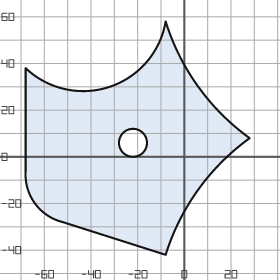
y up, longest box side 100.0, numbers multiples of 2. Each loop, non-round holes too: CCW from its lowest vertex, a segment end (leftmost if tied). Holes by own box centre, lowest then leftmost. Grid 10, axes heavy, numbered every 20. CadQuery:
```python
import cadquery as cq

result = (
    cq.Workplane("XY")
    .moveTo(-8.0, -42.0)
    .threePointArc((6.0, -14.0), (28.0, 8.0))
    .threePointArc((6.0, 30.0), (-8.0, 58.0))
    .threePointArc((-32.0, 30.0), (-68.0, 38.0))
    .lineTo(-68.0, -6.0)
    .threePointArc((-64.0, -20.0), (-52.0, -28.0))
    .close()
    .moveTo(-22.0, 6.0)
    .circle(6.0)
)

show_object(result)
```